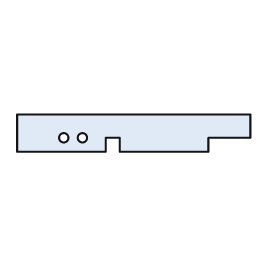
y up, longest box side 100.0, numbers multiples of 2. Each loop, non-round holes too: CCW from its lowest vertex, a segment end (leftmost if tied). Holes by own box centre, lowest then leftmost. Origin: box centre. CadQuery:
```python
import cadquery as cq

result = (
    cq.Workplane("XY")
    .moveTo(-50.0, -8.0)
    .lineTo(-12.0, -8.0)
    .lineTo(-12.0, -2.0)
    .lineTo(-6.0, -2.0)
    .lineTo(-6.0, -8.0)
    .lineTo(32.0, -8.0)
    .lineTo(32.0, -2.0)
    .lineTo(50.0, -2.0)
    .lineTo(50.0, 8.0)
    .lineTo(-50.0, 8.0)
    .close()
    .moveTo(-30.0, -2.0)
    .circle(2.0)
    .moveTo(-22.0, -2.0)
    .circle(2.0)
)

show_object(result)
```